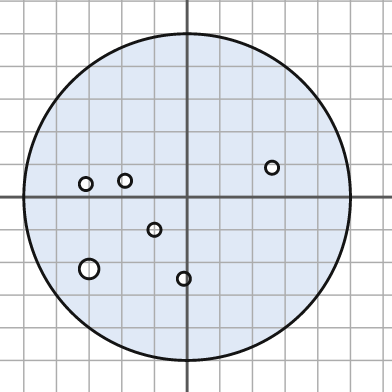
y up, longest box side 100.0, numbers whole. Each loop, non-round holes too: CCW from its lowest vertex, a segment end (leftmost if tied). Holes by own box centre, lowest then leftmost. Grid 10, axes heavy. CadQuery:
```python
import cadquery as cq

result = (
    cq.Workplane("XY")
    .moveTo(0.0, 0.0)
    .circle(50.0)
    .moveTo(-1.0, -25.0)
    .circle(2.0)
    .moveTo(-30.0, -22.0)
    .circle(3.0)
    .moveTo(-10.0, -10.0)
    .circle(2.0)
    .moveTo(-31.0, 4.0)
    .circle(2.0)
    .moveTo(-19.0, 5.0)
    .circle(2.0)
    .moveTo(26.0, 9.0)
    .circle(2.0)
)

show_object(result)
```